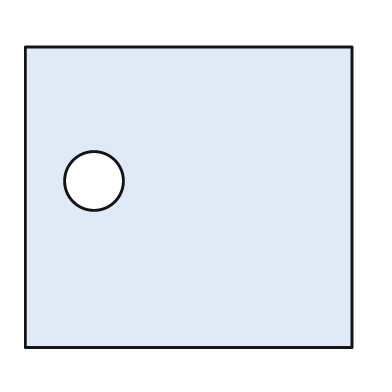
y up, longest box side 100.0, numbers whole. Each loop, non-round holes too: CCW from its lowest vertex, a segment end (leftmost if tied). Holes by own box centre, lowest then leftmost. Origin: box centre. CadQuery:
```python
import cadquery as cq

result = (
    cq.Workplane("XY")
    .moveTo(-50.0, -46.0)
    .lineTo(50.0, -46.0)
    .lineTo(50.0, 46.0)
    .lineTo(-50.0, 46.0)
    .close()
    .moveTo(-29.0, 5.0)
    .circle(9.0)
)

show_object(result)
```